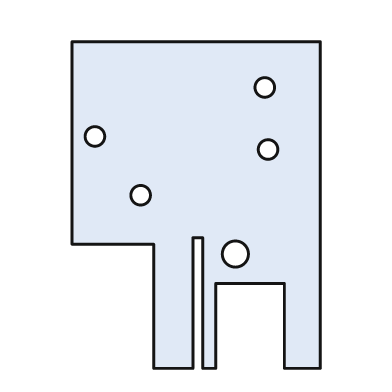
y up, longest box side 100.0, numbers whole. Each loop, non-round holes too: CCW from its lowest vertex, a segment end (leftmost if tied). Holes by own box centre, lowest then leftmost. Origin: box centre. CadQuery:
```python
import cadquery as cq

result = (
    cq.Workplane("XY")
    .moveTo(-13.0, -50.0)
    .lineTo(-1.0, -50.0)
    .lineTo(-1.0, -10.0)
    .lineTo(2.0, -10.0)
    .lineTo(2.0, -50.0)
    .lineTo(6.0, -50.0)
    .lineTo(6.0, -24.0)
    .lineTo(27.0, -24.0)
    .lineTo(27.0, -50.0)
    .lineTo(38.0, -50.0)
    .lineTo(38.0, 50.0)
    .lineTo(-38.0, 50.0)
    .lineTo(-38.0, -12.0)
    .lineTo(-13.0, -12.0)
    .close()
    .moveTo(12.0, -15.0)
    .circle(4.0)
    .moveTo(-17.0, 3.0)
    .circle(3.0)
    .moveTo(22.0, 17.0)
    .circle(3.0)
    .moveTo(-31.0, 21.0)
    .circle(3.0)
    .moveTo(21.0, 36.0)
    .circle(3.0)
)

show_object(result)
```